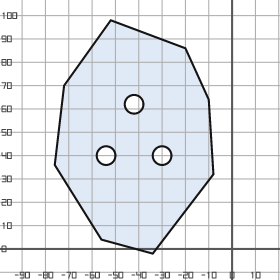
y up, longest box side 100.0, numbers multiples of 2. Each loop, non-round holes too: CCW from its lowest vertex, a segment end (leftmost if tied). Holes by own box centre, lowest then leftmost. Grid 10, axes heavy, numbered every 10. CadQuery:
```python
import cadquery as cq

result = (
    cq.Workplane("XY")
    .moveTo(-34.0, -2.0)
    .lineTo(-8.0, 32.0)
    .lineTo(-10.0, 64.0)
    .lineTo(-20.0, 86.0)
    .lineTo(-52.0, 98.0)
    .lineTo(-72.0, 70.0)
    .lineTo(-76.0, 36.0)
    .lineTo(-56.0, 4.0)
    .close()
    .moveTo(-54.0, 40.0)
    .circle(4.0)
    .moveTo(-30.0, 40.0)
    .circle(4.0)
    .moveTo(-42.0, 62.0)
    .circle(4.0)
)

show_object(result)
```